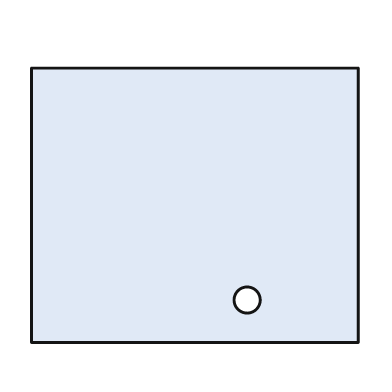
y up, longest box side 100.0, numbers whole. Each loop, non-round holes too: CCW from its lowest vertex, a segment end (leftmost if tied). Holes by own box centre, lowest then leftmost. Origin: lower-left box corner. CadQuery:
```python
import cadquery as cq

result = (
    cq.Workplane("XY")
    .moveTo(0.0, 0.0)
    .lineTo(100.0, 0.0)
    .lineTo(100.0, 84.0)
    .lineTo(0.0, 84.0)
    .close()
    .moveTo(66.0, 13.0)
    .circle(4.0)
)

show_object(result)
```